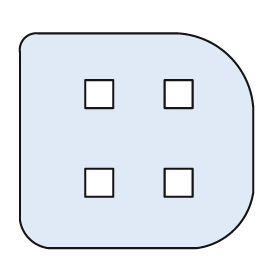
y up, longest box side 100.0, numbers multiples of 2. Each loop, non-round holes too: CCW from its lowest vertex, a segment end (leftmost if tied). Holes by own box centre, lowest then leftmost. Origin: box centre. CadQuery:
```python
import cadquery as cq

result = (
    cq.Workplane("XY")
    .moveTo(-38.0, -46.0)
    .lineTo(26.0, -46.0)
    .threePointArc((42.0, -38.0), (50.0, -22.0))
    .lineTo(50.0, 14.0)
    .threePointArc((40.0, 36.0), (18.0, 46.0))
    .lineTo(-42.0, 46.0)
    .threePointArc((-48.0, 44.0), (-50.0, 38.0))
    .lineTo(-50.0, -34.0)
    .threePointArc((-46.0, -42.0), (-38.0, -46.0))
    .close()
    .moveTo(-22.0, -24.0)
    .lineTo(-10.0, -24.0)
    .lineTo(-10.0, -12.0)
    .lineTo(-22.0, -12.0)
    .close()
    .moveTo(12.0, -24.0)
    .lineTo(24.0, -24.0)
    .lineTo(24.0, -12.0)
    .lineTo(12.0, -12.0)
    .close()
    .moveTo(-22.0, 14.0)
    .lineTo(-10.0, 14.0)
    .lineTo(-10.0, 26.0)
    .lineTo(-22.0, 26.0)
    .close()
    .moveTo(12.0, 14.0)
    .lineTo(24.0, 14.0)
    .lineTo(24.0, 26.0)
    .lineTo(12.0, 26.0)
    .close()
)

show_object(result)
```